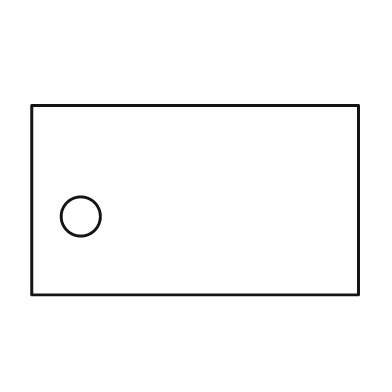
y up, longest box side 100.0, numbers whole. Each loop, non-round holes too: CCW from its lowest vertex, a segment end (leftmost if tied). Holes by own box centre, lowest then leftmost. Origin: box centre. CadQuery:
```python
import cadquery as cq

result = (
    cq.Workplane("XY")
    .moveTo(-50.0, -29.0)
    .lineTo(50.0, -29.0)
    .lineTo(50.0, 29.0)
    .lineTo(-50.0, 29.0)
    .close()
    .moveTo(-35.0, -5.0)
    .circle(6.0)
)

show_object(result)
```